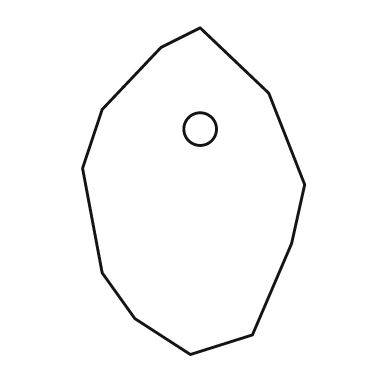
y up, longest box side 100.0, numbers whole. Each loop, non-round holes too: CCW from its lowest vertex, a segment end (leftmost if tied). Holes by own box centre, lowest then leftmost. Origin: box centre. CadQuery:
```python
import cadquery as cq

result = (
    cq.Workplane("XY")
    .moveTo(-1.0, -50.0)
    .lineTo(18.0, -44.0)
    .lineTo(30.0, -16.0)
    .lineTo(34.0, 2.0)
    .lineTo(23.0, 30.0)
    .lineTo(2.0, 50.0)
    .lineTo(-10.0, 44.0)
    .lineTo(-28.0, 25.0)
    .lineTo(-34.0, 7.0)
    .lineTo(-28.0, -25.0)
    .lineTo(-18.0, -39.0)
    .close()
    .moveTo(2.0, 19.0)
    .circle(5.0)
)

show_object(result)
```